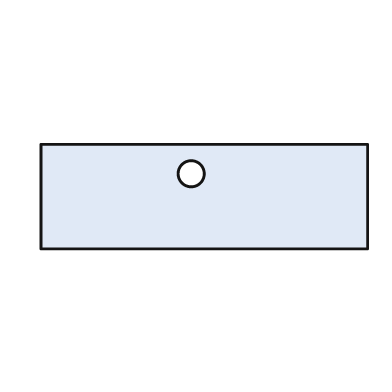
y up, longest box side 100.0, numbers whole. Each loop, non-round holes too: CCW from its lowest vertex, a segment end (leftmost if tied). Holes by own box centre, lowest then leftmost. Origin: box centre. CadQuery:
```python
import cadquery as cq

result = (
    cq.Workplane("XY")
    .moveTo(-50.0, -16.0)
    .lineTo(50.0, -16.0)
    .lineTo(50.0, 16.0)
    .lineTo(-50.0, 16.0)
    .close()
    .moveTo(-4.0, 7.0)
    .circle(4.0)
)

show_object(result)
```